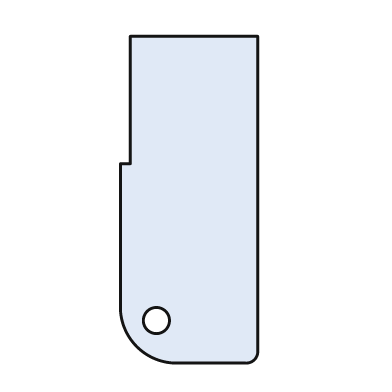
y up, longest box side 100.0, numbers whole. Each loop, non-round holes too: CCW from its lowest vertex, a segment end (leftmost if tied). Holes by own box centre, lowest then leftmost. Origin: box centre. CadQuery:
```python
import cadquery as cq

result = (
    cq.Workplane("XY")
    .moveTo(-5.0, -50.0)
    .lineTo(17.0, -50.0)
    .threePointArc((20.0, -49.0), (21.0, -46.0))
    .lineTo(21.0, 50.0)
    .lineTo(-18.0, 50.0)
    .lineTo(-18.0, 11.0)
    .lineTo(-21.0, 11.0)
    .lineTo(-21.0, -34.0)
    .threePointArc((-16.0, -45.0), (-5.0, -50.0))
    .close()
    .moveTo(-10.0, -37.0)
    .circle(4.0)
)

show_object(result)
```